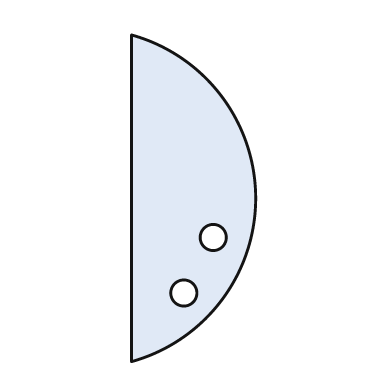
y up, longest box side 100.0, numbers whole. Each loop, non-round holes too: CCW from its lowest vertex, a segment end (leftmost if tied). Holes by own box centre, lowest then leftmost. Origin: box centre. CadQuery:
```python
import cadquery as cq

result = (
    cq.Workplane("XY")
    .moveTo(-19.0, -50.0)
    .threePointArc((19.0, 0.0), (-19.0, 50.0))
    .close()
    .moveTo(-3.0, -29.0)
    .circle(4.0)
    .moveTo(6.0, -12.0)
    .circle(4.0)
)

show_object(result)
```